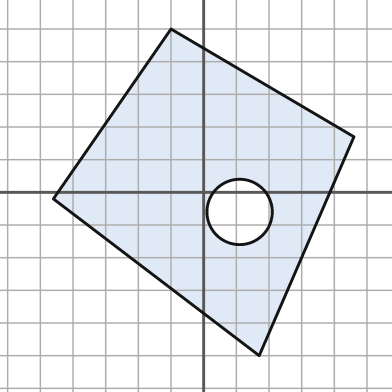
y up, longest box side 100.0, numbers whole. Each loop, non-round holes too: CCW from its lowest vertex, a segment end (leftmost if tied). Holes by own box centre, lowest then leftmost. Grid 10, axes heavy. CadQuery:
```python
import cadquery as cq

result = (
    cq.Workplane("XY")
    .moveTo(17.0, -50.0)
    .lineTo(46.0, 17.0)
    .lineTo(-10.0, 50.0)
    .lineTo(-46.0, -2.0)
    .close()
    .moveTo(11.0, -6.0)
    .circle(10.0)
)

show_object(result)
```